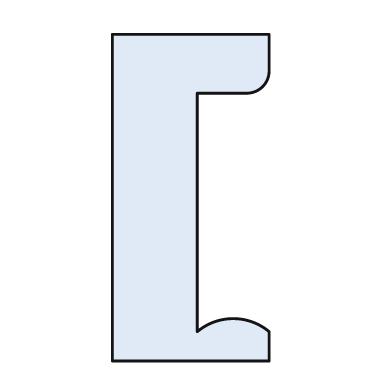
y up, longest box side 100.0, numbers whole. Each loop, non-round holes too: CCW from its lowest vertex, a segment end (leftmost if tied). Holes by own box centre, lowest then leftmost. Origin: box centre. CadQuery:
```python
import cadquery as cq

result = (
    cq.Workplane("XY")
    .moveTo(-24.0, -50.0)
    .lineTo(24.0, -50.0)
    .lineTo(24.0, -41.0)
    .threePointArc((13.0, -37.0), (2.0, -41.0))
    .lineTo(2.0, 32.0)
    .lineTo(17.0, 32.0)
    .threePointArc((22.0, 34.0), (24.0, 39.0))
    .lineTo(24.0, 50.0)
    .lineTo(-24.0, 50.0)
    .close()
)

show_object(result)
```